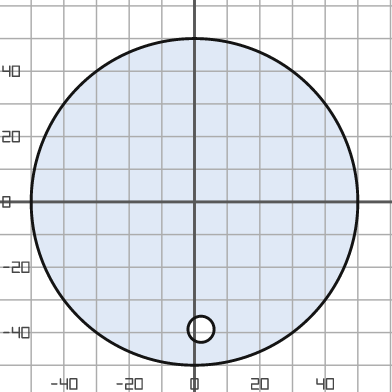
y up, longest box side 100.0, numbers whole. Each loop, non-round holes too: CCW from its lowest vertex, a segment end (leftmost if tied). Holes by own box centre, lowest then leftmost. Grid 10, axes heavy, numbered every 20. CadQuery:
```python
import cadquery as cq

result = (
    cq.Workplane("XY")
    .moveTo(0.0, 0.0)
    .circle(50.0)
    .moveTo(2.0, -39.0)
    .circle(4.0)
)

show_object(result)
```